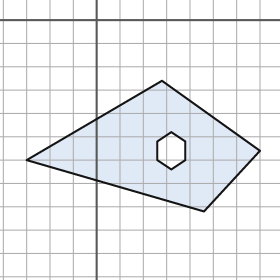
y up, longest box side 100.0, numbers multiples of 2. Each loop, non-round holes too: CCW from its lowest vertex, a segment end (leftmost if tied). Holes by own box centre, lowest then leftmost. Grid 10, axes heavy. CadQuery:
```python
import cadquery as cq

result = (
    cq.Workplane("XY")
    .moveTo(46.0, -82.0)
    .lineTo(70.0, -56.0)
    .lineTo(28.0, -26.0)
    .lineTo(-30.0, -60.0)
    .close()
    .moveTo(32.0, -64.0)
    .lineTo(38.0, -60.0)
    .lineTo(38.0, -52.0)
    .lineTo(32.0, -48.0)
    .lineTo(26.0, -52.0)
    .lineTo(26.0, -60.0)
    .close()
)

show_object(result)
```